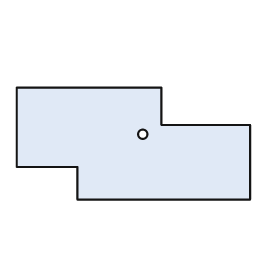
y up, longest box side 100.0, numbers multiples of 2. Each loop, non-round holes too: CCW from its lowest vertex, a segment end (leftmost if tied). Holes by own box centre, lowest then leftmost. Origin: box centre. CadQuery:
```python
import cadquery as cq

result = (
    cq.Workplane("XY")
    .moveTo(-24.0, -24.0)
    .lineTo(50.0, -24.0)
    .lineTo(50.0, 8.0)
    .lineTo(12.0, 8.0)
    .lineTo(12.0, 24.0)
    .lineTo(-50.0, 24.0)
    .lineTo(-50.0, -10.0)
    .lineTo(-24.0, -10.0)
    .close()
    .moveTo(4.0, 4.0)
    .circle(2.0)
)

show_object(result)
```